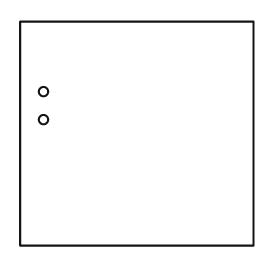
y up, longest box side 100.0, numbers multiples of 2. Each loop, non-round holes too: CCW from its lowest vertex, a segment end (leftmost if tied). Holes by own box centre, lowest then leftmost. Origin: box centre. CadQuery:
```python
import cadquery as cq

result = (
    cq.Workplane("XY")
    .moveTo(-50.0, -48.0)
    .lineTo(50.0, -48.0)
    .lineTo(50.0, 48.0)
    .lineTo(-50.0, 48.0)
    .close()
    .moveTo(-40.0, 6.0)
    .circle(2.0)
    .moveTo(-40.0, 18.0)
    .circle(2.0)
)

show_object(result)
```